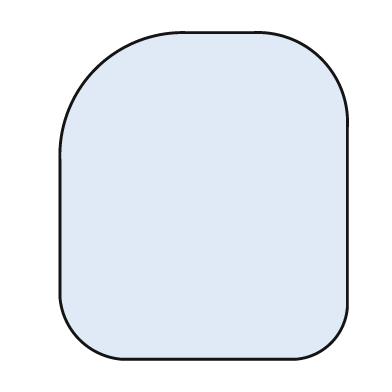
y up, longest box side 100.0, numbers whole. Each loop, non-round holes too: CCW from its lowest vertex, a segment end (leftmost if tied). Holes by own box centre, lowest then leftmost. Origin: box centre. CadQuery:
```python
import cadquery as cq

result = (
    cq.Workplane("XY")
    .moveTo(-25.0, -50.0)
    .lineTo(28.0, -50.0)
    .threePointArc((39.0, -45.0), (44.0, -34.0))
    .lineTo(44.0, 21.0)
    .threePointArc((36.0, 42.0), (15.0, 50.0))
    .lineTo(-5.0, 50.0)
    .threePointArc((-33.0, 39.0), (-44.0, 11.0))
    .lineTo(-44.0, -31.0)
    .threePointArc((-38.0, -44.0), (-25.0, -50.0))
    .close()
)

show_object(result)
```